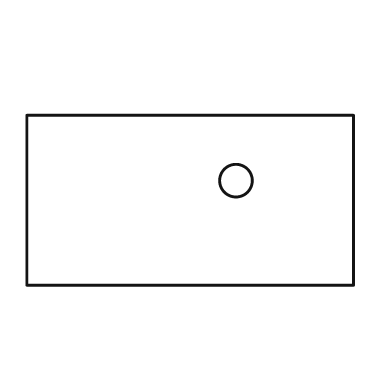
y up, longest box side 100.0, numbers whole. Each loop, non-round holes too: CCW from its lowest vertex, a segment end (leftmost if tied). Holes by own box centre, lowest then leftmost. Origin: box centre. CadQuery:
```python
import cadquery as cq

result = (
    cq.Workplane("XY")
    .moveTo(-50.0, -26.0)
    .lineTo(50.0, -26.0)
    .lineTo(50.0, 26.0)
    .lineTo(-50.0, 26.0)
    .close()
    .moveTo(14.0, 6.0)
    .circle(5.0)
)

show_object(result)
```